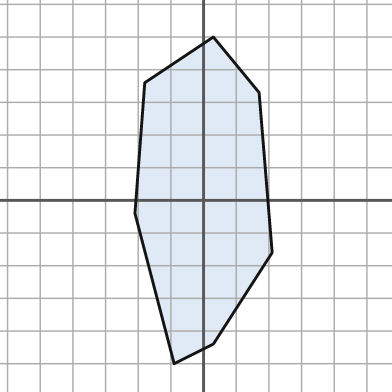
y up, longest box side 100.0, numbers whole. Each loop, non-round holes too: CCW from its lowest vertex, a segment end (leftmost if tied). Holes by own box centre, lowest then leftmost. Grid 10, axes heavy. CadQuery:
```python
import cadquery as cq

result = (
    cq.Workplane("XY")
    .moveTo(-9.0, -50.0)
    .lineTo(3.0, -44.0)
    .lineTo(21.0, -16.0)
    .lineTo(17.0, 33.0)
    .lineTo(3.0, 50.0)
    .lineTo(-18.0, 36.0)
    .lineTo(-21.0, -4.0)
    .close()
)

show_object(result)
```